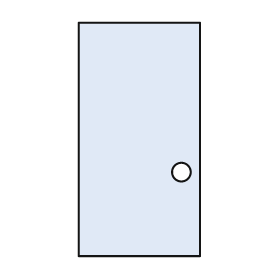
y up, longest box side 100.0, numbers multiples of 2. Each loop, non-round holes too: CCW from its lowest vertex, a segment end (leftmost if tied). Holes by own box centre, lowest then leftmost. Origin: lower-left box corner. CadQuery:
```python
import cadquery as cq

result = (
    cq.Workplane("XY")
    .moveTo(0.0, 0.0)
    .lineTo(52.0, 0.0)
    .lineTo(52.0, 100.0)
    .lineTo(0.0, 100.0)
    .close()
    .moveTo(44.0, 36.0)
    .circle(4.0)
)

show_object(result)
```